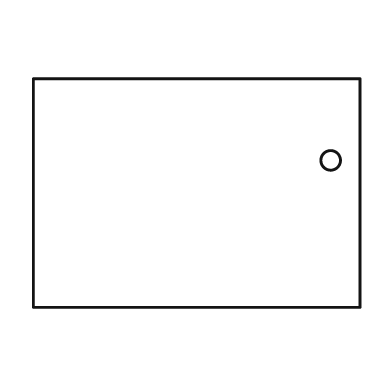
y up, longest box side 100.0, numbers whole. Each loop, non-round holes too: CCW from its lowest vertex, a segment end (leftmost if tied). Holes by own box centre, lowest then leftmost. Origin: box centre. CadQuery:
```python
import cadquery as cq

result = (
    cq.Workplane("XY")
    .moveTo(-50.0, -35.0)
    .lineTo(50.0, -35.0)
    .lineTo(50.0, 35.0)
    .lineTo(-50.0, 35.0)
    .close()
    .moveTo(41.0, 10.0)
    .circle(3.0)
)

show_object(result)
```